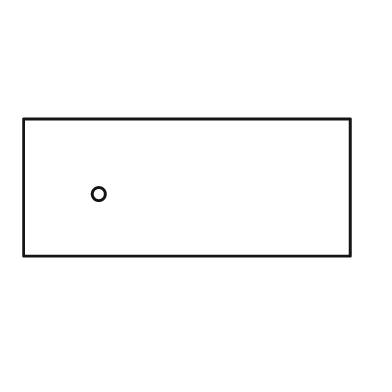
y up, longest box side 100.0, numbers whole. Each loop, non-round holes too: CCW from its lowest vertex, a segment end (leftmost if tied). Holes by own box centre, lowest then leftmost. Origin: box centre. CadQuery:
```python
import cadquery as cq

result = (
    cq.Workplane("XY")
    .moveTo(-50.0, -21.0)
    .lineTo(50.0, -21.0)
    .lineTo(50.0, 21.0)
    .lineTo(-50.0, 21.0)
    .close()
    .moveTo(-27.0, -2.0)
    .circle(2.0)
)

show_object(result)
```